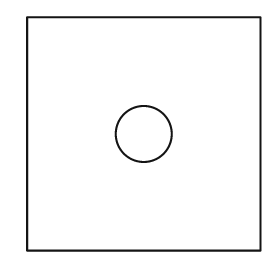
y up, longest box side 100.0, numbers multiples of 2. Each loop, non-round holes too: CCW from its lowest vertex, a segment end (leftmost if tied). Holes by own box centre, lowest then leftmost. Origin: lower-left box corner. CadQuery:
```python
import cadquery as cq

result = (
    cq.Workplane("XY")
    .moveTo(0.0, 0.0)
    .lineTo(100.0, 0.0)
    .lineTo(100.0, 100.0)
    .lineTo(0.0, 100.0)
    .close()
    .moveTo(50.0, 50.0)
    .circle(12.0)
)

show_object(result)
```